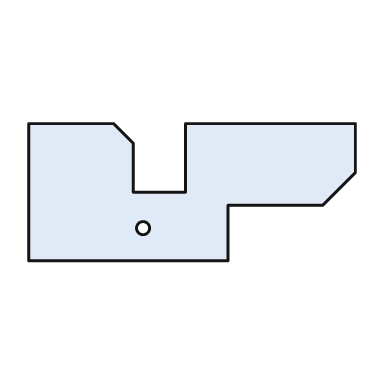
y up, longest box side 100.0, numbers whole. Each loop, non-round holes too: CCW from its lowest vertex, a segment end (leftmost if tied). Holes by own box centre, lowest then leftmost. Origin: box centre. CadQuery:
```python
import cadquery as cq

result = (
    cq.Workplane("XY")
    .moveTo(-50.0, -21.0)
    .lineTo(11.0, -21.0)
    .lineTo(11.0, -4.0)
    .lineTo(40.0, -4.0)
    .lineTo(50.0, 6.0)
    .lineTo(50.0, 21.0)
    .lineTo(-2.0, 21.0)
    .lineTo(-2.0, 0.0)
    .lineTo(-18.0, 0.0)
    .lineTo(-18.0, 15.0)
    .lineTo(-24.0, 21.0)
    .lineTo(-50.0, 21.0)
    .close()
    .moveTo(-15.0, -11.0)
    .circle(2.0)
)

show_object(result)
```